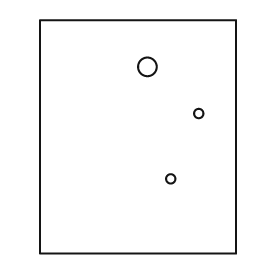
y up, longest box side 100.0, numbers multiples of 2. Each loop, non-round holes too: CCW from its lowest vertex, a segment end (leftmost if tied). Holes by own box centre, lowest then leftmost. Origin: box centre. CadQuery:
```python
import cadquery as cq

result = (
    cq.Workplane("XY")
    .moveTo(-42.0, -50.0)
    .lineTo(42.0, -50.0)
    .lineTo(42.0, 50.0)
    .lineTo(-42.0, 50.0)
    .close()
    .moveTo(14.0, -18.0)
    .circle(2.0)
    .moveTo(26.0, 10.0)
    .circle(2.0)
    .moveTo(4.0, 30.0)
    .circle(4.0)
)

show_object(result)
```